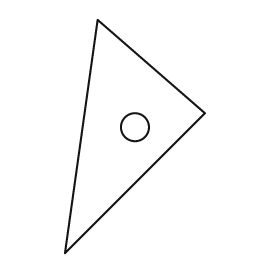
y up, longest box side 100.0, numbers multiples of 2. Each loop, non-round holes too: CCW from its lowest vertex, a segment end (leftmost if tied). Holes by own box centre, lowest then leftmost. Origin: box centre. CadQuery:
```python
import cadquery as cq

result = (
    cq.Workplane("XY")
    .moveTo(-30.0, -50.0)
    .lineTo(30.0, 10.0)
    .lineTo(-16.0, 50.0)
    .close()
    .moveTo(0.0, 4.0)
    .circle(6.0)
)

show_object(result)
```